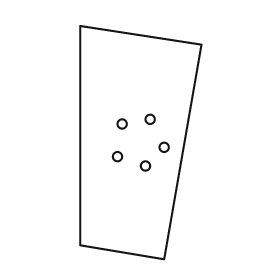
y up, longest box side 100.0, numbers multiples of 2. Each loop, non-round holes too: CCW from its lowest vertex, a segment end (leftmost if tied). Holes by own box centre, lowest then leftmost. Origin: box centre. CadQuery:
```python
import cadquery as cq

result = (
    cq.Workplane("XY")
    .moveTo(10.0, -50.0)
    .lineTo(26.0, 42.0)
    .lineTo(-26.0, 50.0)
    .lineTo(-26.0, -44.0)
    .close()
    .moveTo(2.0, -10.0)
    .circle(2.0)
    .moveTo(-10.0, -6.0)
    .circle(2.0)
    .moveTo(10.0, -2.0)
    .circle(2.0)
    .moveTo(-8.0, 8.0)
    .circle(2.0)
    .moveTo(4.0, 10.0)
    .circle(2.0)
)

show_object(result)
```